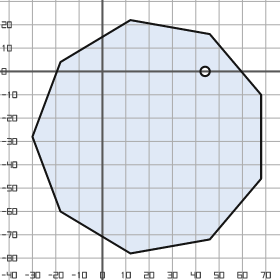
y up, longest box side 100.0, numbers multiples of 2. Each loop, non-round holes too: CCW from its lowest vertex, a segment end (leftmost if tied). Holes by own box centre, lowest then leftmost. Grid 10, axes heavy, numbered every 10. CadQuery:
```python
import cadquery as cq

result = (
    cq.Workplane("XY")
    .moveTo(12.0, -78.0)
    .lineTo(46.0, -72.0)
    .lineTo(68.0, -46.0)
    .lineTo(68.0, -10.0)
    .lineTo(46.0, 16.0)
    .lineTo(12.0, 22.0)
    .lineTo(-18.0, 4.0)
    .lineTo(-30.0, -28.0)
    .lineTo(-18.0, -60.0)
    .close()
    .moveTo(44.0, 0.0)
    .circle(2.0)
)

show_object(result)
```